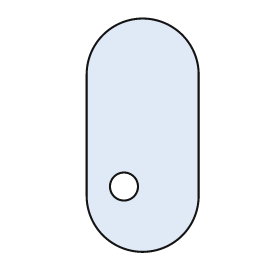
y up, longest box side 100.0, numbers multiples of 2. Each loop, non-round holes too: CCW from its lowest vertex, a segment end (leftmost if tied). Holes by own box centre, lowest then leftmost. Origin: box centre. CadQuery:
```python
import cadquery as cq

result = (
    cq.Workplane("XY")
    .moveTo(-24.0, -26.0)
    .threePointArc((0.0, -50.0), (24.0, -26.0))
    .lineTo(24.0, 26.0)
    .threePointArc((0.0, 50.0), (-24.0, 26.0))
    .close()
    .moveTo(-8.0, -22.0)
    .circle(6.0)
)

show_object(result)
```